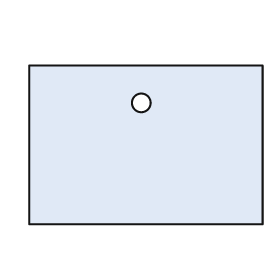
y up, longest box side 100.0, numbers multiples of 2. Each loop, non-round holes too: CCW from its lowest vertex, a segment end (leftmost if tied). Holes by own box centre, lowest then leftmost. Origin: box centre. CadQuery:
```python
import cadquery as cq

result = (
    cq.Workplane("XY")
    .moveTo(-50.0, -34.0)
    .lineTo(50.0, -34.0)
    .lineTo(50.0, 34.0)
    .lineTo(-50.0, 34.0)
    .close()
    .moveTo(-2.0, 18.0)
    .circle(4.0)
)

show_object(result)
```